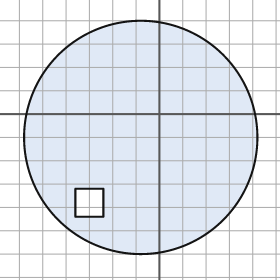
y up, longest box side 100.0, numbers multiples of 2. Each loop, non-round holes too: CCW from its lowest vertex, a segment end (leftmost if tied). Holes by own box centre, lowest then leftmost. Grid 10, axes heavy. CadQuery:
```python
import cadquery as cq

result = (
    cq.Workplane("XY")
    .moveTo(-8.0, -10.0)
    .circle(50.0)
    .moveTo(-36.0, -44.0)
    .lineTo(-24.0, -44.0)
    .lineTo(-24.0, -32.0)
    .lineTo(-36.0, -32.0)
    .close()
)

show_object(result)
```